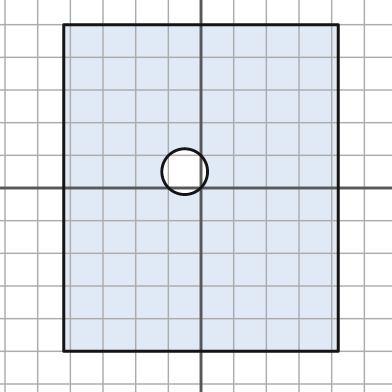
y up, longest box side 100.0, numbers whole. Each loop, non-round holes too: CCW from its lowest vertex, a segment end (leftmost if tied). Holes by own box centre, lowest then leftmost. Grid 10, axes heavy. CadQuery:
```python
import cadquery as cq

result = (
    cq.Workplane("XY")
    .moveTo(-42.0, -50.0)
    .lineTo(42.0, -50.0)
    .lineTo(42.0, 50.0)
    .lineTo(-42.0, 50.0)
    .close()
    .moveTo(-5.0, 5.0)
    .circle(7.0)
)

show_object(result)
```